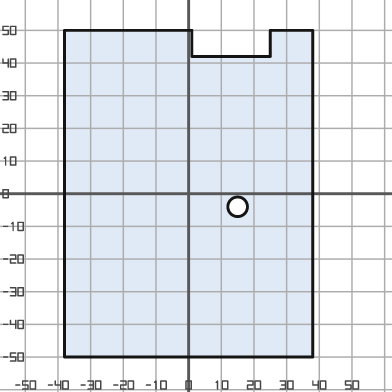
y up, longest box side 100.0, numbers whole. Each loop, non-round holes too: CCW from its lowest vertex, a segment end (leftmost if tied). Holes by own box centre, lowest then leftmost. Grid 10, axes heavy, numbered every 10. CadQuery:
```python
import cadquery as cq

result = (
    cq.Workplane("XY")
    .moveTo(-38.0, -50.0)
    .lineTo(38.0, -50.0)
    .lineTo(38.0, 50.0)
    .lineTo(25.0, 50.0)
    .lineTo(25.0, 42.0)
    .lineTo(1.0, 42.0)
    .lineTo(1.0, 50.0)
    .lineTo(-38.0, 50.0)
    .close()
    .moveTo(15.0, -4.0)
    .circle(3.0)
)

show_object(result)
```